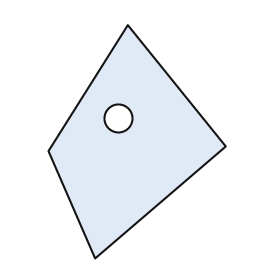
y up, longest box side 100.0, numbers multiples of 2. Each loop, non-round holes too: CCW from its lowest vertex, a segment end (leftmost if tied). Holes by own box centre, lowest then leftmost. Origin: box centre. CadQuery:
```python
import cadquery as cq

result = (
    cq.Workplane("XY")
    .moveTo(-18.0, -50.0)
    .lineTo(38.0, -2.0)
    .lineTo(-4.0, 50.0)
    .lineTo(-38.0, -4.0)
    .close()
    .moveTo(-8.0, 10.0)
    .circle(6.0)
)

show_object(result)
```